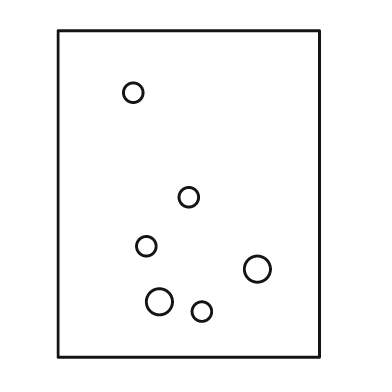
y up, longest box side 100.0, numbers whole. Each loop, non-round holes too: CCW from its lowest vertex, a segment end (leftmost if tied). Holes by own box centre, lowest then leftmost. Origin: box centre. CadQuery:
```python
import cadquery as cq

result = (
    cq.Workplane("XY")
    .moveTo(-40.0, -50.0)
    .lineTo(40.0, -50.0)
    .lineTo(40.0, 50.0)
    .lineTo(-40.0, 50.0)
    .close()
    .moveTo(4.0, -36.0)
    .circle(3.0)
    .moveTo(-9.0, -33.0)
    .circle(4.0)
    .moveTo(21.0, -23.0)
    .circle(4.0)
    .moveTo(-13.0, -16.0)
    .circle(3.0)
    .moveTo(0.0, -1.0)
    .circle(3.0)
    .moveTo(-17.0, 31.0)
    .circle(3.0)
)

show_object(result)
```